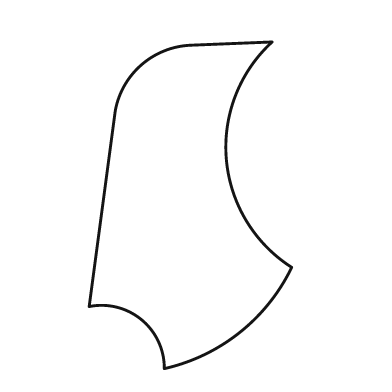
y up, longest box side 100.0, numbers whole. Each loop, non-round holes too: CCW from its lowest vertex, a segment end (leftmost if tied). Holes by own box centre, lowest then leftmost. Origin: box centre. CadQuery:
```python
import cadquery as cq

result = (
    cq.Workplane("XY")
    .moveTo(-8.0, -50.0)
    .threePointArc((15.0, -39.0), (31.0, -19.0))
    .threePointArc((11.0, 14.0), (25.0, 50.0))
    .lineTo(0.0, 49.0)
    .threePointArc((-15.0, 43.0), (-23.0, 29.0))
    .lineTo(-31.0, -31.0)
    .threePointArc((-15.0, -35.0), (-8.0, -50.0))
    .close()
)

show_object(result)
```